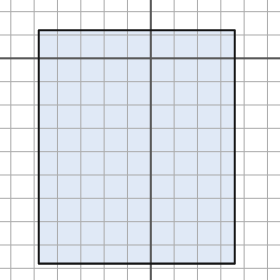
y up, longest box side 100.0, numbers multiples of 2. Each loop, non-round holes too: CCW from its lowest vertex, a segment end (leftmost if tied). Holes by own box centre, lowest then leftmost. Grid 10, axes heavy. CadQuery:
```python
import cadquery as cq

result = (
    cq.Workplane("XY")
    .moveTo(-48.0, -88.0)
    .lineTo(36.0, -88.0)
    .lineTo(36.0, 12.0)
    .lineTo(-48.0, 12.0)
    .close()
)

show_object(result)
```